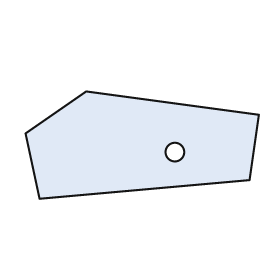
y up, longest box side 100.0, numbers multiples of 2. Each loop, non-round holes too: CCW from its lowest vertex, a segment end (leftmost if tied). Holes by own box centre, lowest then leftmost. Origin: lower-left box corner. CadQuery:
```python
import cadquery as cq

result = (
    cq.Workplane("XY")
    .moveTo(6.0, 0.0)
    .lineTo(96.0, 8.0)
    .lineTo(100.0, 36.0)
    .lineTo(26.0, 46.0)
    .lineTo(0.0, 28.0)
    .close()
    .moveTo(64.0, 20.0)
    .circle(4.0)
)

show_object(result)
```